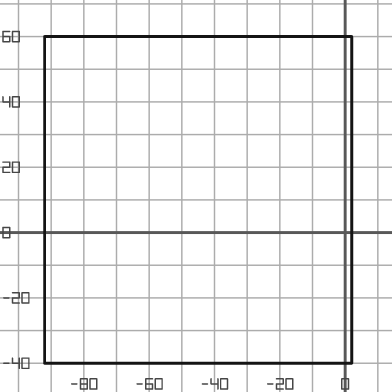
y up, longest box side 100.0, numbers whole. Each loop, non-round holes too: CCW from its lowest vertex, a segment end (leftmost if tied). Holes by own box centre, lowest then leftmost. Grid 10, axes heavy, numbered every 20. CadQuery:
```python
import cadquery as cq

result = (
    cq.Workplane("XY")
    .moveTo(-92.0, -40.0)
    .lineTo(2.0, -40.0)
    .lineTo(2.0, 60.0)
    .lineTo(-92.0, 60.0)
    .close()
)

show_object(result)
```